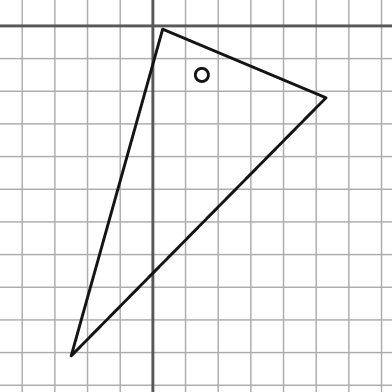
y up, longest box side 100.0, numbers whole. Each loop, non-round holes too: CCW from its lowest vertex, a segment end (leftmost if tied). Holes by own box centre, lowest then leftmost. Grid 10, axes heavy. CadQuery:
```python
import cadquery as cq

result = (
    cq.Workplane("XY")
    .moveTo(-25.0, -101.0)
    .lineTo(53.0, -22.0)
    .lineTo(3.0, -1.0)
    .close()
    .moveTo(15.0, -15.0)
    .circle(2.0)
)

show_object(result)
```